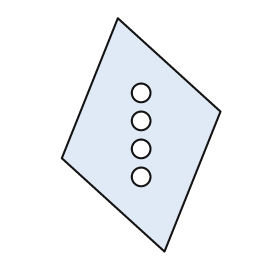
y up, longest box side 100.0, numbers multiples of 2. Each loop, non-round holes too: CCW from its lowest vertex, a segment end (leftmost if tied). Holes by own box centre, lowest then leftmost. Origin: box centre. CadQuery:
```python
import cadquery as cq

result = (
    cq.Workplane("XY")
    .moveTo(10.0, -50.0)
    .lineTo(34.0, 10.0)
    .lineTo(-10.0, 50.0)
    .lineTo(-34.0, -10.0)
    .close()
    .moveTo(0.0, -18.0)
    .circle(4.0)
    .moveTo(0.0, -6.0)
    .circle(4.0)
    .moveTo(0.0, 6.0)
    .circle(4.0)
    .moveTo(0.0, 18.0)
    .circle(4.0)
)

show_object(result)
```